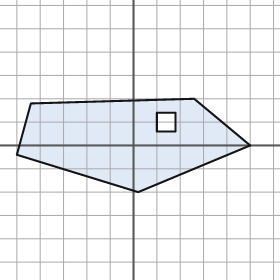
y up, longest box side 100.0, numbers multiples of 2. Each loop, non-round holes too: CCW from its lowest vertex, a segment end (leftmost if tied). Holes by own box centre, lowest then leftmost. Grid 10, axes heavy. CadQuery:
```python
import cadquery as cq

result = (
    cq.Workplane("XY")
    .moveTo(2.0, -20.0)
    .lineTo(50.0, 0.0)
    .lineTo(26.0, 20.0)
    .lineTo(-44.0, 18.0)
    .lineTo(-50.0, -4.0)
    .close()
    .moveTo(10.0, 6.0)
    .lineTo(18.0, 6.0)
    .lineTo(18.0, 14.0)
    .lineTo(10.0, 14.0)
    .close()
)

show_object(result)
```